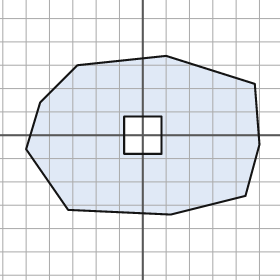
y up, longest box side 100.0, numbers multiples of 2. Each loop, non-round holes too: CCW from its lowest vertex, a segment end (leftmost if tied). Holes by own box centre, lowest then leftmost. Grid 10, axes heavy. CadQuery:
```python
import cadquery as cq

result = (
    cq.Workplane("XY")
    .moveTo(12.0, -34.0)
    .lineTo(44.0, -26.0)
    .lineTo(50.0, -4.0)
    .lineTo(48.0, 22.0)
    .lineTo(10.0, 34.0)
    .lineTo(-28.0, 30.0)
    .lineTo(-44.0, 14.0)
    .lineTo(-50.0, -6.0)
    .lineTo(-32.0, -32.0)
    .close()
    .moveTo(-8.0, -8.0)
    .lineTo(8.0, -8.0)
    .lineTo(8.0, 8.0)
    .lineTo(-8.0, 8.0)
    .close()
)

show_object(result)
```